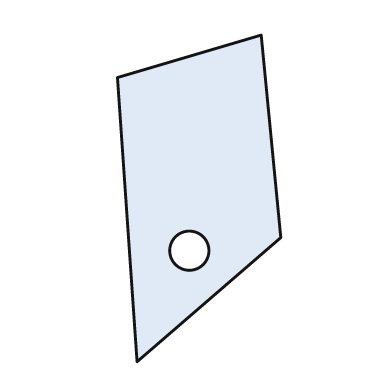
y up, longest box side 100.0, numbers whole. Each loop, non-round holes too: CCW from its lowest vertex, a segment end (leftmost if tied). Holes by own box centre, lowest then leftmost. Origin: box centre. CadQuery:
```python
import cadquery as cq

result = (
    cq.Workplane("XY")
    .moveTo(-19.0, -50.0)
    .lineTo(25.0, -12.0)
    .lineTo(19.0, 50.0)
    .lineTo(-25.0, 37.0)
    .close()
    .moveTo(-3.0, -16.0)
    .circle(6.0)
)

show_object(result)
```